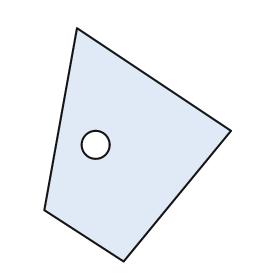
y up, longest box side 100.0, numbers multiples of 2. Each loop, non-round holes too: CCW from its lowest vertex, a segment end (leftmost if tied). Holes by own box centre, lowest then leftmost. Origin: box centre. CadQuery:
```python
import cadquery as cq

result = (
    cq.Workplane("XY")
    .moveTo(-6.0, -50.0)
    .lineTo(40.0, 6.0)
    .lineTo(-26.0, 50.0)
    .lineTo(-40.0, -28.0)
    .close()
    .moveTo(-18.0, 0.0)
    .circle(6.0)
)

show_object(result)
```